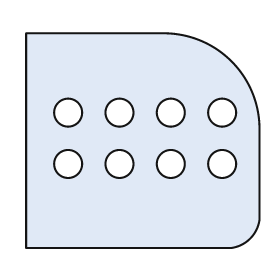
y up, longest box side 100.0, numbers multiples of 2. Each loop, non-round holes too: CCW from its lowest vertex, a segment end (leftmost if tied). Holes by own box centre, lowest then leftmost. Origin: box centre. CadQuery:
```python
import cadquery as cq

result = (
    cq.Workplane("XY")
    .moveTo(-50.0, -46.0)
    .lineTo(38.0, -46.0)
    .threePointArc((46.0, -42.0), (50.0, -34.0))
    .lineTo(50.0, 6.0)
    .threePointArc((38.0, 34.0), (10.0, 46.0))
    .lineTo(-50.0, 46.0)
    .close()
    .moveTo(-32.0, -10.0)
    .circle(6.0)
    .moveTo(-10.0, -10.0)
    .circle(6.0)
    .moveTo(12.0, -10.0)
    .circle(6.0)
    .moveTo(34.0, -10.0)
    .circle(6.0)
    .moveTo(-32.0, 12.0)
    .circle(6.0)
    .moveTo(-10.0, 12.0)
    .circle(6.0)
    .moveTo(12.0, 12.0)
    .circle(6.0)
    .moveTo(34.0, 12.0)
    .circle(6.0)
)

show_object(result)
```